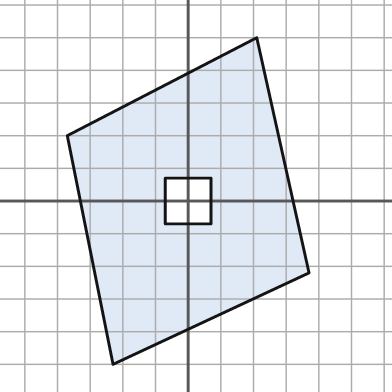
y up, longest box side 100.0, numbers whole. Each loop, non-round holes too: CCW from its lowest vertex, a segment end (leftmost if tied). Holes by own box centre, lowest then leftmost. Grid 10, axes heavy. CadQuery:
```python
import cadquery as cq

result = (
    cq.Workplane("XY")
    .moveTo(-23.0, -50.0)
    .lineTo(37.0, -22.0)
    .lineTo(21.0, 50.0)
    .lineTo(-37.0, 20.0)
    .close()
    .moveTo(-7.0, -7.0)
    .lineTo(7.0, -7.0)
    .lineTo(7.0, 7.0)
    .lineTo(-7.0, 7.0)
    .close()
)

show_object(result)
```